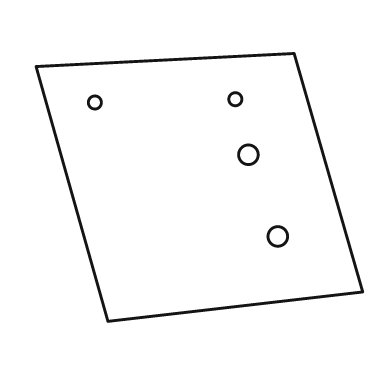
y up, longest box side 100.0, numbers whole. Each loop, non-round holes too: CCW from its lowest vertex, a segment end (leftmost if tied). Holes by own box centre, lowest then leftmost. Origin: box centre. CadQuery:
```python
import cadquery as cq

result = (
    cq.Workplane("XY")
    .moveTo(-28.0, -41.0)
    .lineTo(50.0, -32.0)
    .lineTo(29.0, 41.0)
    .lineTo(-50.0, 37.0)
    .close()
    .moveTo(24.0, -15.0)
    .circle(3.0)
    .moveTo(15.0, 10.0)
    .circle(3.0)
    .moveTo(-32.0, 26.0)
    .circle(2.0)
    .moveTo(11.0, 27.0)
    .circle(2.0)
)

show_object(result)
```